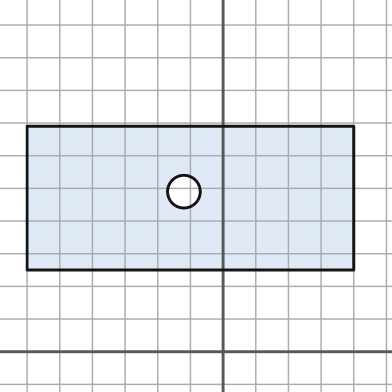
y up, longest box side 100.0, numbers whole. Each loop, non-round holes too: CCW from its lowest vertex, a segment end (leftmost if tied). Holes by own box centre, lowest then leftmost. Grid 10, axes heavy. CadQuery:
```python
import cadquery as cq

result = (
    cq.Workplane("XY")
    .moveTo(-60.0, 25.0)
    .lineTo(40.0, 25.0)
    .lineTo(40.0, 69.0)
    .lineTo(-60.0, 69.0)
    .close()
    .moveTo(-12.0, 49.0)
    .circle(5.0)
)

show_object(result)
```